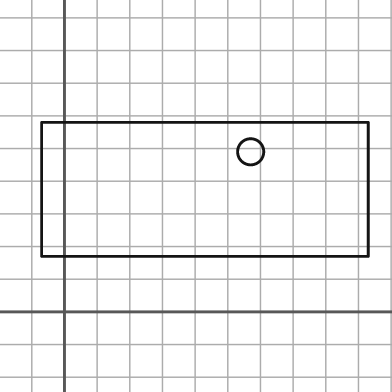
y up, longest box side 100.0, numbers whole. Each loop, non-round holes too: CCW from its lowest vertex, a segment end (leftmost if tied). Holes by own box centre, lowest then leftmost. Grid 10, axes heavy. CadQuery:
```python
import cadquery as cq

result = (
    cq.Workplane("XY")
    .moveTo(-7.0, 17.0)
    .lineTo(93.0, 17.0)
    .lineTo(93.0, 58.0)
    .lineTo(-7.0, 58.0)
    .close()
    .moveTo(57.0, 49.0)
    .circle(4.0)
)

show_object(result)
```